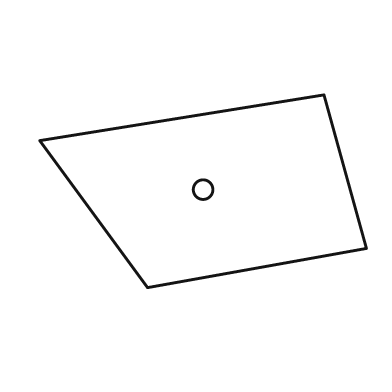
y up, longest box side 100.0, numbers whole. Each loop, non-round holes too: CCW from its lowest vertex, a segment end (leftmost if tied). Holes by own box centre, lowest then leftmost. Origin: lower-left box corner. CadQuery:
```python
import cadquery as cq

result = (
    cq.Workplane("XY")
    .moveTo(33.0, 0.0)
    .lineTo(100.0, 12.0)
    .lineTo(87.0, 59.0)
    .lineTo(0.0, 45.0)
    .close()
    .moveTo(50.0, 30.0)
    .circle(3.0)
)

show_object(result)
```